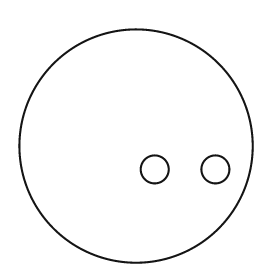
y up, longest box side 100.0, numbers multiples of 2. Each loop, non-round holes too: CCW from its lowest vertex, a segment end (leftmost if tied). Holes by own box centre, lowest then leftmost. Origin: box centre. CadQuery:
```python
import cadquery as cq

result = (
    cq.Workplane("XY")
    .moveTo(0.0, 0.0)
    .circle(50.0)
    .moveTo(8.0, -10.0)
    .circle(6.0)
    .moveTo(34.0, -10.0)
    .circle(6.0)
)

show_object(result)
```